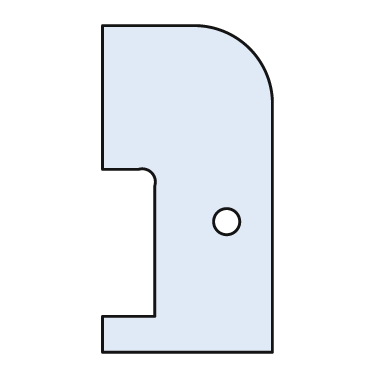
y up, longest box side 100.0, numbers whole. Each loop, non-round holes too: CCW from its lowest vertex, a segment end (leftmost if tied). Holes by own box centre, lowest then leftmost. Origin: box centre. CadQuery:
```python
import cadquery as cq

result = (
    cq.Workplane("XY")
    .moveTo(-26.0, -50.0)
    .lineTo(26.0, -50.0)
    .lineTo(26.0, 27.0)
    .threePointArc((19.0, 43.0), (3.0, 50.0))
    .lineTo(-26.0, 50.0)
    .lineTo(-26.0, 6.0)
    .lineTo(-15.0, 6.0)
    .threePointArc((-11.0, 5.0), (-10.0, 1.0))
    .lineTo(-10.0, -39.0)
    .lineTo(-26.0, -39.0)
    .close()
    .moveTo(12.0, -10.0)
    .circle(4.0)
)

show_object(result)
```